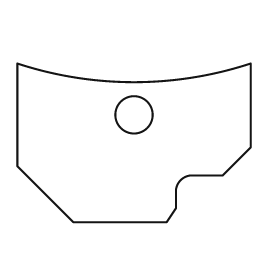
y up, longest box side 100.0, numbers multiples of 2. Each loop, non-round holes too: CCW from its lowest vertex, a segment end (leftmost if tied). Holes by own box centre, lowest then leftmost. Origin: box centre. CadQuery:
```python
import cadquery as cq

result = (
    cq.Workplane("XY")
    .moveTo(-26.0, -34.0)
    .lineTo(14.0, -34.0)
    .lineTo(18.0, -28.0)
    .lineTo(18.0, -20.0)
    .threePointArc((20.0, -16.0), (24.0, -14.0))
    .lineTo(38.0, -14.0)
    .lineTo(50.0, -2.0)
    .lineTo(50.0, 34.0)
    .threePointArc((0.0, 26.0), (-50.0, 34.0))
    .lineTo(-50.0, -10.0)
    .close()
    .moveTo(0.0, 12.0)
    .circle(8.0)
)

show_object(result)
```